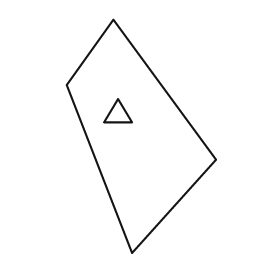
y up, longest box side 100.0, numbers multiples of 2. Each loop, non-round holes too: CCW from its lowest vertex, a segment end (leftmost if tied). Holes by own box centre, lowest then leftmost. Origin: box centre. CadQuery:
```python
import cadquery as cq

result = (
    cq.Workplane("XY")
    .moveTo(-4.0, -50.0)
    .lineTo(32.0, -10.0)
    .lineTo(-12.0, 50.0)
    .lineTo(-32.0, 22.0)
    .close()
    .moveTo(-16.0, 6.0)
    .lineTo(-4.0, 6.0)
    .lineTo(-10.0, 16.0)
    .close()
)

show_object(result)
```